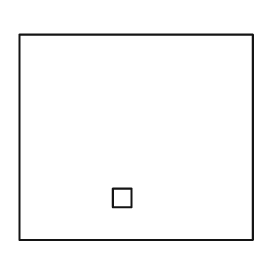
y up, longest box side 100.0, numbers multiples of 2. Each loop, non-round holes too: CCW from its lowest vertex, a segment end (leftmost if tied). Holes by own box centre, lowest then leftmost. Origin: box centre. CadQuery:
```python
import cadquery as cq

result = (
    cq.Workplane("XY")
    .moveTo(-50.0, -44.0)
    .lineTo(50.0, -44.0)
    .lineTo(50.0, 44.0)
    .lineTo(-50.0, 44.0)
    .close()
    .moveTo(-10.0, -30.0)
    .lineTo(-2.0, -30.0)
    .lineTo(-2.0, -22.0)
    .lineTo(-10.0, -22.0)
    .close()
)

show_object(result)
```